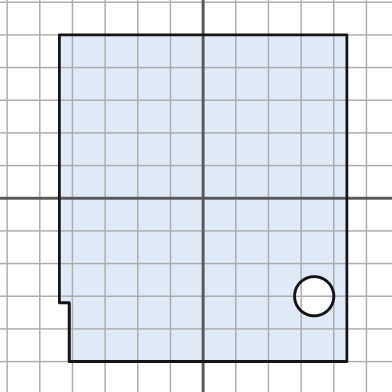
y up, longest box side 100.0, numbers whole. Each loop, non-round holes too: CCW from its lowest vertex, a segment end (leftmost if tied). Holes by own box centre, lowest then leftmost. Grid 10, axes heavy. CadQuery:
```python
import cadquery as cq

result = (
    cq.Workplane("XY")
    .moveTo(-41.0, -50.0)
    .lineTo(44.0, -50.0)
    .lineTo(44.0, 50.0)
    .lineTo(-44.0, 50.0)
    .lineTo(-44.0, -32.0)
    .lineTo(-41.0, -32.0)
    .close()
    .moveTo(34.0, -30.0)
    .circle(6.0)
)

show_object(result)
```